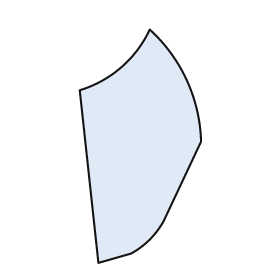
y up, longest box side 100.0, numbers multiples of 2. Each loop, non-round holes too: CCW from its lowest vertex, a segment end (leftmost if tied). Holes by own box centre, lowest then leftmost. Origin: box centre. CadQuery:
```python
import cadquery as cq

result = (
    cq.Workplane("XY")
    .moveTo(-18.0, -50.0)
    .lineTo(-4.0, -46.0)
    .threePointArc((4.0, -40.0), (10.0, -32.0))
    .lineTo(26.0, 2.0)
    .threePointArc((20.0, 28.0), (4.0, 50.0))
    .threePointArc((-8.0, 34.0), (-26.0, 24.0))
    .close()
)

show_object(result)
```